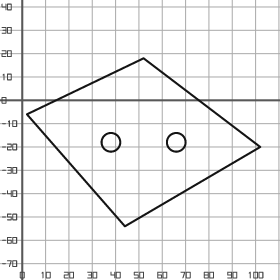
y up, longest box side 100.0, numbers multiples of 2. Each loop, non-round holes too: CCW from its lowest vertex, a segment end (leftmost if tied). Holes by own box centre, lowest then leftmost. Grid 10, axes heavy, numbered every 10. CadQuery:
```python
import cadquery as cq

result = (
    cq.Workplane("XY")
    .moveTo(44.0, -54.0)
    .lineTo(102.0, -20.0)
    .lineTo(52.0, 18.0)
    .lineTo(2.0, -6.0)
    .close()
    .moveTo(38.0, -18.0)
    .circle(4.0)
    .moveTo(66.0, -18.0)
    .circle(4.0)
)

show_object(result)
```